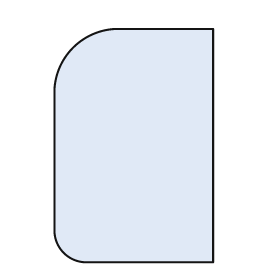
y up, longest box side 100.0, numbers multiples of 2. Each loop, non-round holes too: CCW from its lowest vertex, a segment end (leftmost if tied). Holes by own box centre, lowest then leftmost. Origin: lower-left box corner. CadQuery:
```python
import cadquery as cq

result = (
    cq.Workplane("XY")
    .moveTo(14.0, 0.0)
    .lineTo(68.0, 0.0)
    .lineTo(68.0, 100.0)
    .lineTo(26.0, 100.0)
    .threePointArc((8.0, 92.0), (0.0, 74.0))
    .lineTo(0.0, 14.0)
    .threePointArc((4.0, 4.0), (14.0, 0.0))
    .close()
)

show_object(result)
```